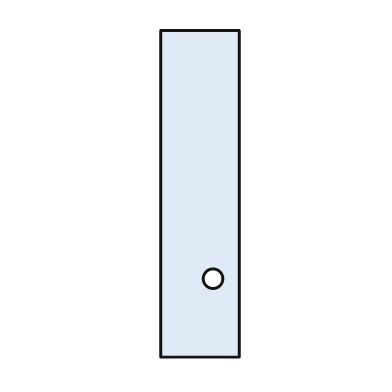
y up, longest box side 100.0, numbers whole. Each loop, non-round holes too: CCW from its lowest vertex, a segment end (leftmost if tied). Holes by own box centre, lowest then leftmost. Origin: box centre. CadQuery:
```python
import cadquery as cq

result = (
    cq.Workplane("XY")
    .moveTo(-12.0, -50.0)
    .lineTo(12.0, -50.0)
    .lineTo(12.0, 50.0)
    .lineTo(-12.0, 50.0)
    .close()
    .moveTo(4.0, -26.0)
    .circle(3.0)
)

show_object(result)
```